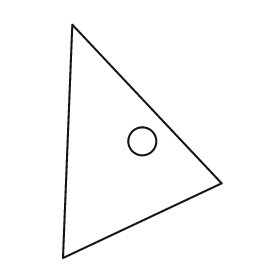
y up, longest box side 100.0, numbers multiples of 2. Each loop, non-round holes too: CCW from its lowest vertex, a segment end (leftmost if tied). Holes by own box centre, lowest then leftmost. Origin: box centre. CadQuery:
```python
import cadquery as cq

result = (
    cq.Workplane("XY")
    .moveTo(-34.0, -50.0)
    .lineTo(34.0, -18.0)
    .lineTo(-30.0, 50.0)
    .close()
    .moveTo(0.0, 0.0)
    .circle(6.0)
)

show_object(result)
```